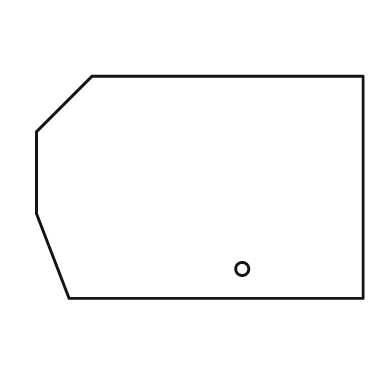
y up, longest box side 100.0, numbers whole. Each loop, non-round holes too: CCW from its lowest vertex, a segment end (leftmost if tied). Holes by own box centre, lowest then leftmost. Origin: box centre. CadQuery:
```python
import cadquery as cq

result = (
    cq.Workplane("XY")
    .moveTo(-40.0, -34.0)
    .lineTo(50.0, -34.0)
    .lineTo(50.0, 34.0)
    .lineTo(-33.0, 34.0)
    .lineTo(-50.0, 17.0)
    .lineTo(-50.0, -8.0)
    .close()
    .moveTo(13.0, -25.0)
    .circle(2.0)
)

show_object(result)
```